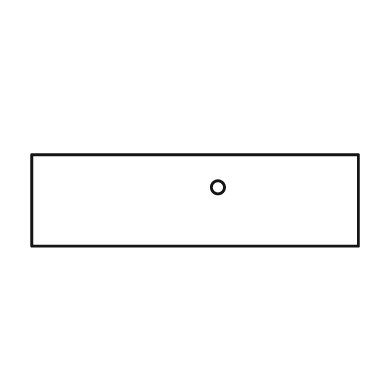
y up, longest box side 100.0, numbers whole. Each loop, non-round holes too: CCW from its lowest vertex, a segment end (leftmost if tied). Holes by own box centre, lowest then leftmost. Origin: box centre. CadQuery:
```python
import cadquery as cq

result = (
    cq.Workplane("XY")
    .moveTo(-50.0, -14.0)
    .lineTo(50.0, -14.0)
    .lineTo(50.0, 14.0)
    .lineTo(-50.0, 14.0)
    .close()
    .moveTo(7.0, 4.0)
    .circle(2.0)
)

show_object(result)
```